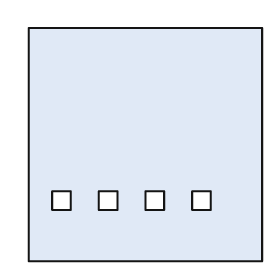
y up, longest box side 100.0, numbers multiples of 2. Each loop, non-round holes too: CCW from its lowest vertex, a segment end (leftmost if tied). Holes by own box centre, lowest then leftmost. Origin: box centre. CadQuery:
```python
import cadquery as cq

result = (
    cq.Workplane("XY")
    .moveTo(-50.0, -50.0)
    .lineTo(50.0, -50.0)
    .lineTo(50.0, 50.0)
    .lineTo(-50.0, 50.0)
    .close()
    .moveTo(-40.0, -28.0)
    .lineTo(-32.0, -28.0)
    .lineTo(-32.0, -20.0)
    .lineTo(-40.0, -20.0)
    .close()
    .moveTo(-20.0, -28.0)
    .lineTo(-12.0, -28.0)
    .lineTo(-12.0, -20.0)
    .lineTo(-20.0, -20.0)
    .close()
    .moveTo(0.0, -28.0)
    .lineTo(8.0, -28.0)
    .lineTo(8.0, -20.0)
    .lineTo(0.0, -20.0)
    .close()
    .moveTo(20.0, -28.0)
    .lineTo(28.0, -28.0)
    .lineTo(28.0, -20.0)
    .lineTo(20.0, -20.0)
    .close()
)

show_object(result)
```